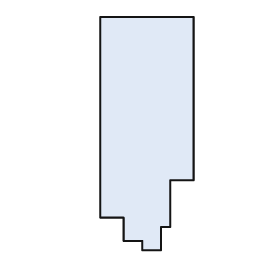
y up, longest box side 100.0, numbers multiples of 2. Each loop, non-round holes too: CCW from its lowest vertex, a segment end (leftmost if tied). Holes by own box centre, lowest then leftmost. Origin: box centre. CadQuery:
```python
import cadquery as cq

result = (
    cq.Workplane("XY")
    .moveTo(-2.0, -50.0)
    .lineTo(6.0, -50.0)
    .lineTo(6.0, -40.0)
    .lineTo(10.0, -40.0)
    .lineTo(10.0, -20.0)
    .lineTo(20.0, -20.0)
    .lineTo(20.0, 50.0)
    .lineTo(-20.0, 50.0)
    .lineTo(-20.0, -36.0)
    .lineTo(-10.0, -36.0)
    .lineTo(-10.0, -46.0)
    .lineTo(-2.0, -46.0)
    .close()
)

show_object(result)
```